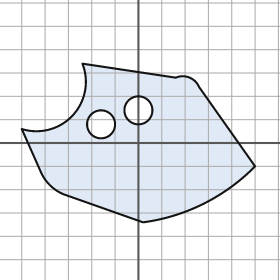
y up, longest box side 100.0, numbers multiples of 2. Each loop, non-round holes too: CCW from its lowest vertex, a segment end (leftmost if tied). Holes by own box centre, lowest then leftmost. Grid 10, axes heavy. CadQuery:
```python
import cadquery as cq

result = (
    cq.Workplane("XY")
    .moveTo(2.0, -34.0)
    .threePointArc((28.0, -26.0), (50.0, -10.0))
    .lineTo(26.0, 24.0)
    .threePointArc((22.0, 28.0), (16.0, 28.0))
    .lineTo(-24.0, 34.0)
    .threePointArc((-28.0, 12.0), (-50.0, 6.0))
    .lineTo(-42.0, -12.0)
    .threePointArc((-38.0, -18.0), (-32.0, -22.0))
    .close()
    .moveTo(-16.0, 8.0)
    .circle(6.0)
    .moveTo(0.0, 14.0)
    .circle(6.0)
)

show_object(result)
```